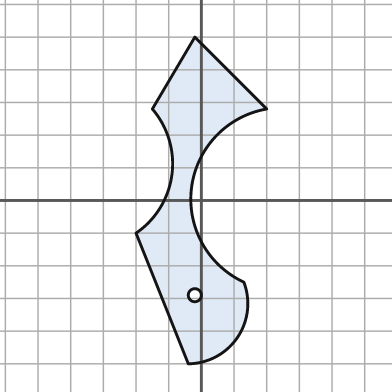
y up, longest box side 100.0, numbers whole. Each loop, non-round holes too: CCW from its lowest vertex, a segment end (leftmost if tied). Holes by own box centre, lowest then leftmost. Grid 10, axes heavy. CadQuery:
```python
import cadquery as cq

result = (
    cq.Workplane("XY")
    .moveTo(-4.0, -50.0)
    .threePointArc((11.0, -42.0), (13.0, -25.0))
    .threePointArc((-3.0, 4.0), (20.0, 28.0))
    .lineTo(-2.0, 50.0)
    .lineTo(-15.0, 28.0)
    .threePointArc((-9.0, 8.0), (-20.0, -10.0))
    .close()
    .moveTo(-2.0, -29.0)
    .circle(2.0)
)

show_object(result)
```